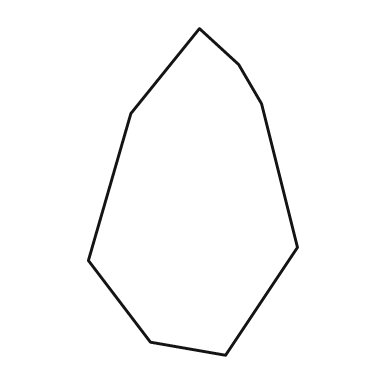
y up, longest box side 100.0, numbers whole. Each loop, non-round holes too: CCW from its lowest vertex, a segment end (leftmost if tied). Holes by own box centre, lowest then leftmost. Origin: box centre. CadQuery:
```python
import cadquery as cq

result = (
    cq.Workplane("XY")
    .moveTo(10.0, -50.0)
    .lineTo(32.0, -17.0)
    .lineTo(21.0, 27.0)
    .lineTo(14.0, 39.0)
    .lineTo(2.0, 50.0)
    .lineTo(-19.0, 24.0)
    .lineTo(-32.0, -21.0)
    .lineTo(-13.0, -46.0)
    .close()
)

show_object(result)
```